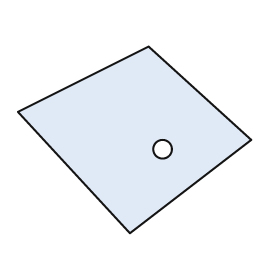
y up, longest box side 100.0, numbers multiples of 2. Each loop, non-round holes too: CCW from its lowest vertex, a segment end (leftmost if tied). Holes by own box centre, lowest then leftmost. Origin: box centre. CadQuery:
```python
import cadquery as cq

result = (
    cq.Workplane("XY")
    .moveTo(-2.0, -40.0)
    .lineTo(50.0, 0.0)
    .lineTo(6.0, 40.0)
    .lineTo(-50.0, 12.0)
    .close()
    .moveTo(12.0, -4.0)
    .circle(4.0)
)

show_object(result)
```